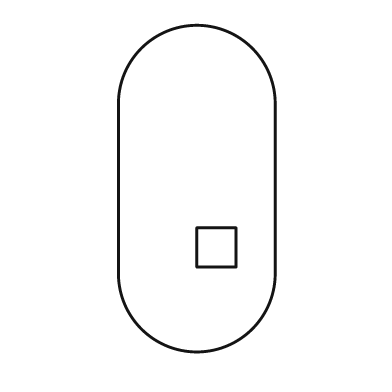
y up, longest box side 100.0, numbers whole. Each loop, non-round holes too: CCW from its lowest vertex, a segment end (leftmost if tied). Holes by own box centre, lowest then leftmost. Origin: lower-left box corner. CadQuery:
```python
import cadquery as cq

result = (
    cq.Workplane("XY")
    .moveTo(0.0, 24.0)
    .threePointArc((24.0, 0.0), (48.0, 24.0))
    .lineTo(48.0, 76.0)
    .threePointArc((24.0, 100.0), (0.0, 76.0))
    .close()
    .moveTo(24.0, 26.0)
    .lineTo(36.0, 26.0)
    .lineTo(36.0, 38.0)
    .lineTo(24.0, 38.0)
    .close()
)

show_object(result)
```